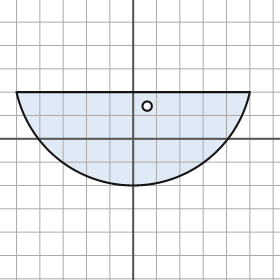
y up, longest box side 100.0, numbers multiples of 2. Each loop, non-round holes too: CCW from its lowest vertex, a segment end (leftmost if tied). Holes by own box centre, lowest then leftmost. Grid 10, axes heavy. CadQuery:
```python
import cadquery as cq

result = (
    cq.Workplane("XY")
    .moveTo(-50.0, 20.0)
    .threePointArc((0.0, -20.0), (50.0, 20.0))
    .close()
    .moveTo(6.0, 14.0)
    .circle(2.0)
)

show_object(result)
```